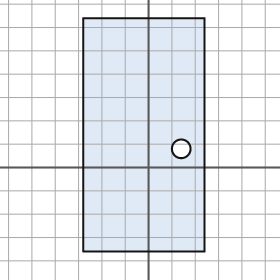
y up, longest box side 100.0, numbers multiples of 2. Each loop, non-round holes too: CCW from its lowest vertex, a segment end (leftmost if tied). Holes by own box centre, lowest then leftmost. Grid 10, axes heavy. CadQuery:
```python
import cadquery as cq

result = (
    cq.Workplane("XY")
    .moveTo(-28.0, -36.0)
    .lineTo(24.0, -36.0)
    .lineTo(24.0, 64.0)
    .lineTo(-28.0, 64.0)
    .close()
    .moveTo(14.0, 8.0)
    .circle(4.0)
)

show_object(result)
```